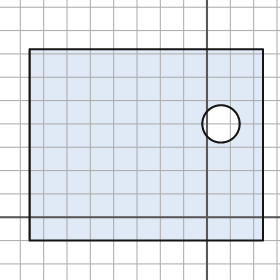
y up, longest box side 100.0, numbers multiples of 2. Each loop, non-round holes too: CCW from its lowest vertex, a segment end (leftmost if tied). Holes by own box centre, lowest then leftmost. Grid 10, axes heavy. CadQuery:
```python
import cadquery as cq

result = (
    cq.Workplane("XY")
    .moveTo(-76.0, -10.0)
    .lineTo(24.0, -10.0)
    .lineTo(24.0, 72.0)
    .lineTo(-76.0, 72.0)
    .close()
    .moveTo(6.0, 40.0)
    .circle(8.0)
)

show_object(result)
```